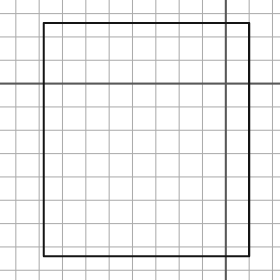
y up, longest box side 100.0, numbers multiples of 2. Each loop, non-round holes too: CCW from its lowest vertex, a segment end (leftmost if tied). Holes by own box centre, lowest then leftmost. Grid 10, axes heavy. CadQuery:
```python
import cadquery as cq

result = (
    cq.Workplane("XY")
    .moveTo(-78.0, -74.0)
    .lineTo(10.0, -74.0)
    .lineTo(10.0, 26.0)
    .lineTo(-78.0, 26.0)
    .close()
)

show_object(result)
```